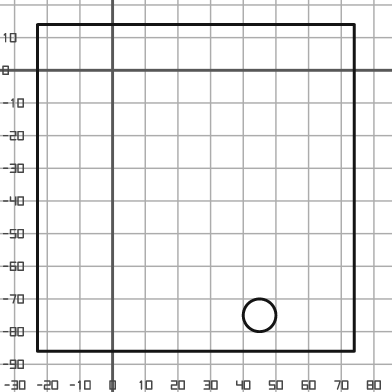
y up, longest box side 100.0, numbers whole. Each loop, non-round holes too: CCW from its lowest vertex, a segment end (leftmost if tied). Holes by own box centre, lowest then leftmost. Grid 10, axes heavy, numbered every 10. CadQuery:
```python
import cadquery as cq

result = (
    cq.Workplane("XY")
    .moveTo(-23.0, -86.0)
    .lineTo(74.0, -86.0)
    .lineTo(74.0, 14.0)
    .lineTo(-23.0, 14.0)
    .close()
    .moveTo(45.0, -75.0)
    .circle(5.0)
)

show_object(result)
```